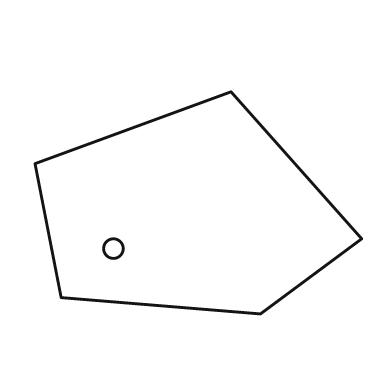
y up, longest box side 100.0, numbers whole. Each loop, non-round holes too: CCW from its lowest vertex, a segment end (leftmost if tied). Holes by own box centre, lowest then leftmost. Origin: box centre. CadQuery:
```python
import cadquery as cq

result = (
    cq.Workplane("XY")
    .moveTo(19.0, -34.0)
    .lineTo(50.0, -11.0)
    .lineTo(10.0, 34.0)
    .lineTo(-50.0, 12.0)
    .lineTo(-42.0, -29.0)
    .close()
    .moveTo(-26.0, -14.0)
    .circle(3.0)
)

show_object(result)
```